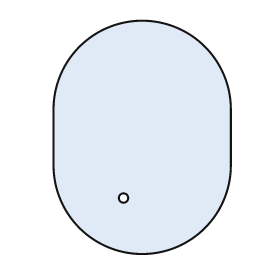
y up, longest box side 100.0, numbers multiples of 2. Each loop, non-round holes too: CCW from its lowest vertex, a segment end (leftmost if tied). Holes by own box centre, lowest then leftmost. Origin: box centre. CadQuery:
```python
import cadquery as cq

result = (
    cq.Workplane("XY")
    .moveTo(-38.0, -12.0)
    .threePointArc((0.0, -50.0), (38.0, -12.0))
    .lineTo(38.0, 12.0)
    .threePointArc((0.0, 50.0), (-38.0, 12.0))
    .close()
    .moveTo(-8.0, -26.0)
    .circle(2.0)
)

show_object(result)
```